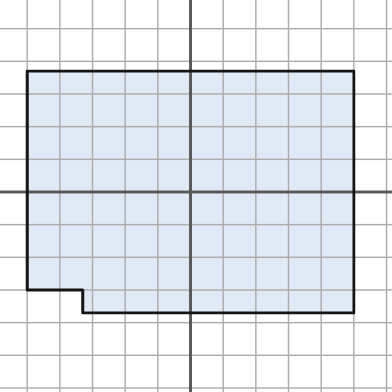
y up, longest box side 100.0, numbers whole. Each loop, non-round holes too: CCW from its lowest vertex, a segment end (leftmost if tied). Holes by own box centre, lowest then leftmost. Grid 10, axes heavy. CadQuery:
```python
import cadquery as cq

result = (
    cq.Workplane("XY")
    .moveTo(-33.0, -37.0)
    .lineTo(50.0, -37.0)
    .lineTo(50.0, 37.0)
    .lineTo(-50.0, 37.0)
    .lineTo(-50.0, -30.0)
    .lineTo(-33.0, -30.0)
    .close()
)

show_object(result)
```